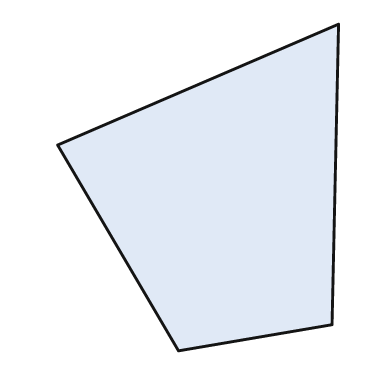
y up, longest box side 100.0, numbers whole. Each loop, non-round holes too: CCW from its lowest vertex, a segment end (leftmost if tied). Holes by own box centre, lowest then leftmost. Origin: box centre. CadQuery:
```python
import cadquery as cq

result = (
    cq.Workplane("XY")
    .moveTo(-6.0, -50.0)
    .lineTo(41.0, -42.0)
    .lineTo(43.0, 50.0)
    .lineTo(-43.0, 13.0)
    .close()
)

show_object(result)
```